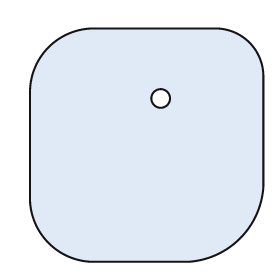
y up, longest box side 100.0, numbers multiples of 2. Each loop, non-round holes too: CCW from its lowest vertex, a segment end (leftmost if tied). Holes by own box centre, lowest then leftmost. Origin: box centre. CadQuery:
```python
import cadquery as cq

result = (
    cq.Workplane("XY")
    .moveTo(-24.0, -50.0)
    .lineTo(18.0, -50.0)
    .threePointArc((40.0, -40.0), (50.0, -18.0))
    .lineTo(50.0, 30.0)
    .threePointArc((44.0, 44.0), (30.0, 50.0))
    .lineTo(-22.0, 50.0)
    .threePointArc((-42.0, 42.0), (-50.0, 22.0))
    .lineTo(-50.0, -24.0)
    .threePointArc((-42.0, -42.0), (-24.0, -50.0))
    .close()
    .moveTo(6.0, 20.0)
    .circle(4.0)
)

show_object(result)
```